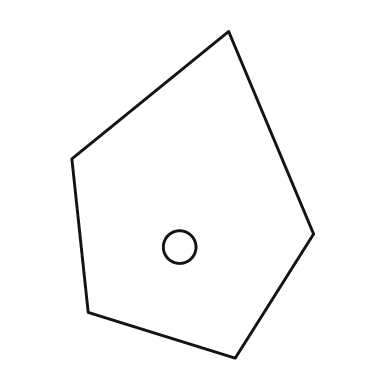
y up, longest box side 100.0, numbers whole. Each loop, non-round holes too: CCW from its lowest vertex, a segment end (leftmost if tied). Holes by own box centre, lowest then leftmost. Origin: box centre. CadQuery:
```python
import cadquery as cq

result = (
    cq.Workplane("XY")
    .moveTo(13.0, -50.0)
    .lineTo(37.0, -12.0)
    .lineTo(11.0, 50.0)
    .lineTo(-37.0, 11.0)
    .lineTo(-32.0, -36.0)
    .close()
    .moveTo(-4.0, -16.0)
    .circle(5.0)
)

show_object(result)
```